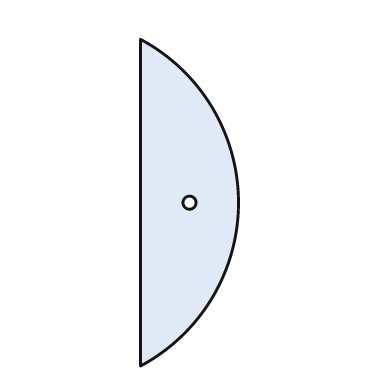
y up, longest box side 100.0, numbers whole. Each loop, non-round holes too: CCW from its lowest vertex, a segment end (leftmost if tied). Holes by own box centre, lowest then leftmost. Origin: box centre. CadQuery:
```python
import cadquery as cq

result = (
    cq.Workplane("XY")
    .moveTo(-15.0, -50.0)
    .threePointArc((15.0, 0.0), (-15.0, 50.0))
    .close()
    .moveTo(0.0, 0.0)
    .circle(2.0)
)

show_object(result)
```